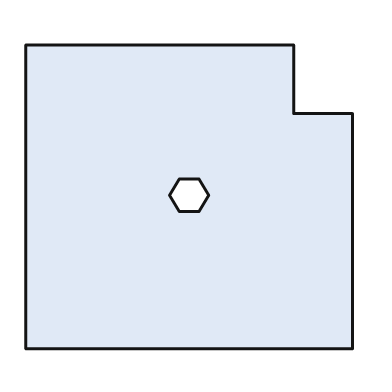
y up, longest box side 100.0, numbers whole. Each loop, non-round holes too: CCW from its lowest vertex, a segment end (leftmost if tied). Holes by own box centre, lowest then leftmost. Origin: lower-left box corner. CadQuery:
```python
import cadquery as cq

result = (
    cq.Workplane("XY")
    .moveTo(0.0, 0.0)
    .lineTo(100.0, 0.0)
    .lineTo(100.0, 72.0)
    .lineTo(82.0, 72.0)
    .lineTo(82.0, 93.0)
    .lineTo(0.0, 93.0)
    .close()
    .moveTo(47.0, 42.0)
    .lineTo(53.0, 42.0)
    .lineTo(56.0, 47.0)
    .lineTo(53.0, 52.0)
    .lineTo(47.0, 52.0)
    .lineTo(44.0, 47.0)
    .close()
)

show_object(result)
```